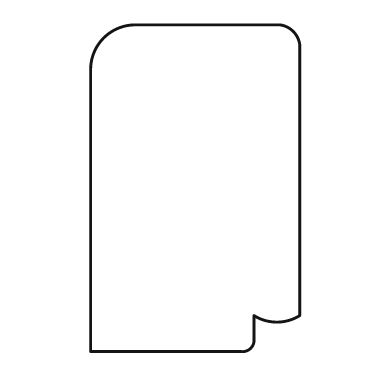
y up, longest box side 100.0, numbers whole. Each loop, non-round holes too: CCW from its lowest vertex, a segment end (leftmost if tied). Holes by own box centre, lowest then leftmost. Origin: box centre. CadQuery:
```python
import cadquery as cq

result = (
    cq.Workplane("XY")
    .moveTo(-32.0, -50.0)
    .lineTo(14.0, -50.0)
    .threePointArc((17.0, -49.0), (18.0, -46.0))
    .lineTo(18.0, -39.0)
    .threePointArc((25.0, -41.0), (32.0, -39.0))
    .lineTo(32.0, 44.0)
    .threePointArc((30.0, 48.0), (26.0, 50.0))
    .lineTo(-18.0, 50.0)
    .threePointArc((-28.0, 46.0), (-32.0, 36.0))
    .close()
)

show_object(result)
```